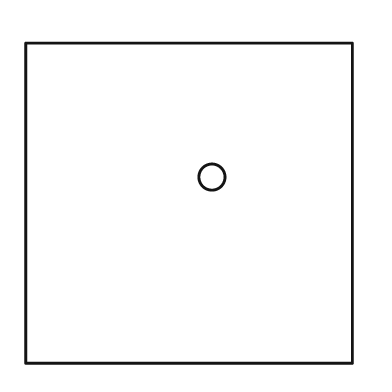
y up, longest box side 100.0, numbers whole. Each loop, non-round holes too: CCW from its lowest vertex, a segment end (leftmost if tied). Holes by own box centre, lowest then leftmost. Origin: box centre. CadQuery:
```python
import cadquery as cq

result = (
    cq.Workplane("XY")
    .moveTo(-50.0, -49.0)
    .lineTo(50.0, -49.0)
    .lineTo(50.0, 49.0)
    .lineTo(-50.0, 49.0)
    .close()
    .moveTo(7.0, 8.0)
    .circle(4.0)
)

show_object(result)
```